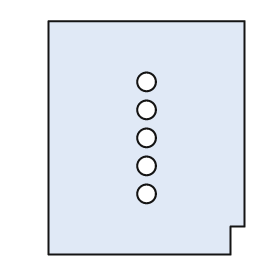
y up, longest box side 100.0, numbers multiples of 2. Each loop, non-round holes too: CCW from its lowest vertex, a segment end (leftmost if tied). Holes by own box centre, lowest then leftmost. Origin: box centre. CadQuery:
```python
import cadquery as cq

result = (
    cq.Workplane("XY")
    .moveTo(-42.0, -50.0)
    .lineTo(36.0, -50.0)
    .lineTo(36.0, -38.0)
    .lineTo(42.0, -38.0)
    .lineTo(42.0, 50.0)
    .lineTo(-42.0, 50.0)
    .close()
    .moveTo(0.0, -24.0)
    .circle(4.0)
    .moveTo(0.0, -12.0)
    .circle(4.0)
    .moveTo(0.0, 0.0)
    .circle(4.0)
    .moveTo(0.0, 12.0)
    .circle(4.0)
    .moveTo(0.0, 24.0)
    .circle(4.0)
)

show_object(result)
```